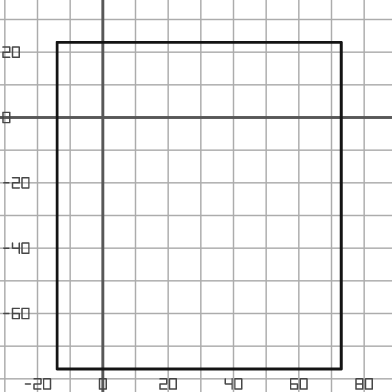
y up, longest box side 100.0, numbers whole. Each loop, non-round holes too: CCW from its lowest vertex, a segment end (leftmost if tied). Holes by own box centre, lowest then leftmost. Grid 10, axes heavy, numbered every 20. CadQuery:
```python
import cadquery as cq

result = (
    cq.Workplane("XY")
    .moveTo(-14.0, -77.0)
    .lineTo(73.0, -77.0)
    .lineTo(73.0, 23.0)
    .lineTo(-14.0, 23.0)
    .close()
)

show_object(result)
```